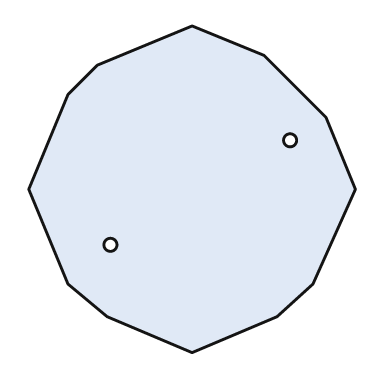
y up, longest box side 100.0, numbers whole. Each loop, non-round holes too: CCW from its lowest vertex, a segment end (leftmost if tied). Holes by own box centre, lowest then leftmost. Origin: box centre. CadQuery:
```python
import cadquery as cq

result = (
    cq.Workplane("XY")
    .moveTo(0.0, -50.0)
    .lineTo(26.0, -39.0)
    .lineTo(37.0, -29.0)
    .lineTo(50.0, 0.0)
    .lineTo(41.0, 22.0)
    .lineTo(22.0, 41.0)
    .lineTo(0.0, 50.0)
    .lineTo(-29.0, 38.0)
    .lineTo(-38.0, 29.0)
    .lineTo(-50.0, 0.0)
    .lineTo(-38.0, -29.0)
    .lineTo(-26.0, -39.0)
    .close()
    .moveTo(-25.0, -17.0)
    .circle(2.0)
    .moveTo(30.0, 15.0)
    .circle(2.0)
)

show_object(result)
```